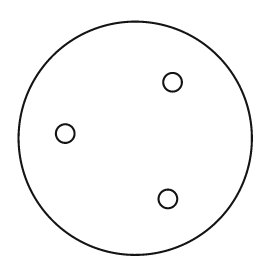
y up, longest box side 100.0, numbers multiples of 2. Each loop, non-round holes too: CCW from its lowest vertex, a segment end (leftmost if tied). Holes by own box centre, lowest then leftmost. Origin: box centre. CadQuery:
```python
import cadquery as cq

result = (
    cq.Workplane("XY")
    .moveTo(0.0, 0.0)
    .circle(50.0)
    .moveTo(14.0, -26.0)
    .circle(4.0)
    .moveTo(-30.0, 2.0)
    .circle(4.0)
    .moveTo(16.0, 24.0)
    .circle(4.0)
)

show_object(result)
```